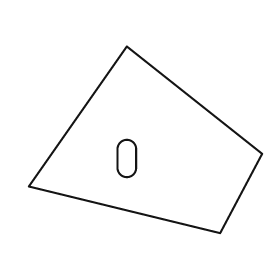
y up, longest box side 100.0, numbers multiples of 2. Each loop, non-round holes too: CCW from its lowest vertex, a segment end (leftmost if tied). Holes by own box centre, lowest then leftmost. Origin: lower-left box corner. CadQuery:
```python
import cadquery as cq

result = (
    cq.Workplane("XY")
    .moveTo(82.0, 0.0)
    .lineTo(100.0, 34.0)
    .lineTo(42.0, 80.0)
    .lineTo(0.0, 20.0)
    .close()
    .moveTo(38.0, 28.0)
    .threePointArc((42.0, 24.0), (46.0, 28.0))
    .lineTo(46.0, 36.0)
    .threePointArc((42.0, 40.0), (38.0, 36.0))
    .close()
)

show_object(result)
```